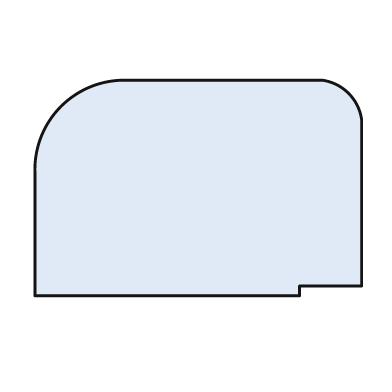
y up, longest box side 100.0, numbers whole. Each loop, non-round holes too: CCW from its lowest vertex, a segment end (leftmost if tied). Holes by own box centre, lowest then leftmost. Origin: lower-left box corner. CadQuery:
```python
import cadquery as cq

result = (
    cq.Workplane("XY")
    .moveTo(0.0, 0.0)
    .lineTo(81.0, 0.0)
    .lineTo(81.0, 3.0)
    .lineTo(100.0, 3.0)
    .lineTo(100.0, 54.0)
    .threePointArc((96.0, 62.0), (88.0, 66.0))
    .lineTo(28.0, 66.0)
    .threePointArc((8.0, 58.0), (0.0, 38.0))
    .close()
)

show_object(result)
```